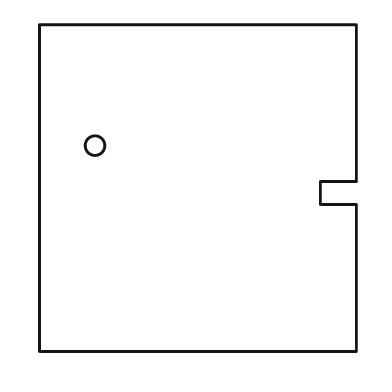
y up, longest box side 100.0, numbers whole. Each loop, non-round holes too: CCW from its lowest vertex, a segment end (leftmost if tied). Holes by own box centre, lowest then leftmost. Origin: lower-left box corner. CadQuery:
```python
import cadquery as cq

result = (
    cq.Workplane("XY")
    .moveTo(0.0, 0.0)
    .lineTo(97.0, 0.0)
    .lineTo(97.0, 45.0)
    .lineTo(86.0, 45.0)
    .lineTo(86.0, 52.0)
    .lineTo(97.0, 52.0)
    .lineTo(97.0, 100.0)
    .lineTo(0.0, 100.0)
    .close()
    .moveTo(17.0, 63.0)
    .circle(3.0)
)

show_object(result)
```